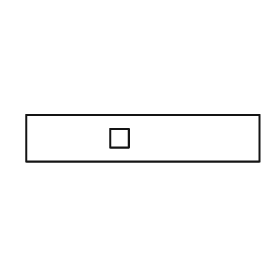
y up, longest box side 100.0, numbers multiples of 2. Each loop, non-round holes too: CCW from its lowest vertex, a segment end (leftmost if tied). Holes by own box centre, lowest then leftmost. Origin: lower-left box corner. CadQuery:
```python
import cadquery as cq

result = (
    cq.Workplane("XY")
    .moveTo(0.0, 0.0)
    .lineTo(100.0, 0.0)
    .lineTo(100.0, 20.0)
    .lineTo(0.0, 20.0)
    .close()
    .moveTo(36.0, 6.0)
    .lineTo(44.0, 6.0)
    .lineTo(44.0, 14.0)
    .lineTo(36.0, 14.0)
    .close()
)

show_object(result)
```